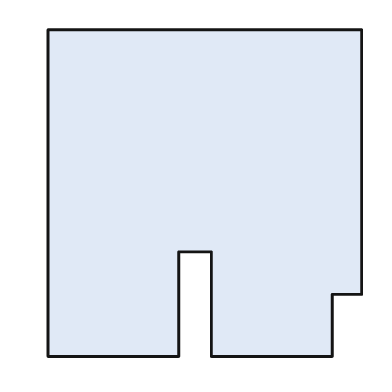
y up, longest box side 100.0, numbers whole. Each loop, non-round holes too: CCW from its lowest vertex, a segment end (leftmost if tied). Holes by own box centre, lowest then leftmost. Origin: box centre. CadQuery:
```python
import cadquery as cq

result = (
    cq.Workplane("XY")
    .moveTo(-48.0, -50.0)
    .lineTo(-8.0, -50.0)
    .lineTo(-8.0, -18.0)
    .lineTo(2.0, -18.0)
    .lineTo(2.0, -50.0)
    .lineTo(39.0, -50.0)
    .lineTo(39.0, -31.0)
    .lineTo(48.0, -31.0)
    .lineTo(48.0, 50.0)
    .lineTo(-48.0, 50.0)
    .close()
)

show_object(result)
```